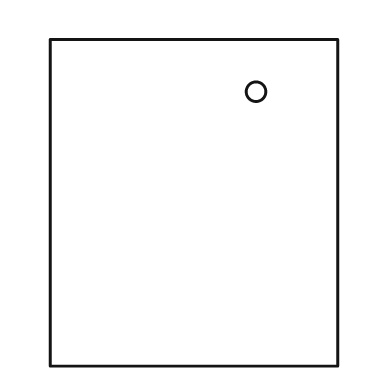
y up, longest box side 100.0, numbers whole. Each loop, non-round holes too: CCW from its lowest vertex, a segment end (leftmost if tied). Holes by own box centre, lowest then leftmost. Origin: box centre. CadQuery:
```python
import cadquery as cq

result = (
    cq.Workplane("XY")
    .moveTo(-44.0, -50.0)
    .lineTo(44.0, -50.0)
    .lineTo(44.0, 50.0)
    .lineTo(-44.0, 50.0)
    .close()
    .moveTo(19.0, 34.0)
    .circle(3.0)
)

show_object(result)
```